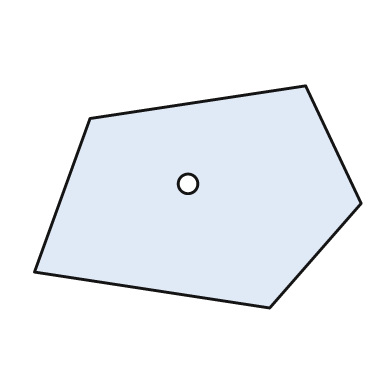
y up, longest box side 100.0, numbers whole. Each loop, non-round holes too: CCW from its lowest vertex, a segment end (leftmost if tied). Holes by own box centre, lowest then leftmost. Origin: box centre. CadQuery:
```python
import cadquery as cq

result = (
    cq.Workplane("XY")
    .moveTo(22.0, -34.0)
    .lineTo(50.0, -2.0)
    .lineTo(33.0, 34.0)
    .lineTo(-33.0, 24.0)
    .lineTo(-50.0, -23.0)
    .close()
    .moveTo(-3.0, 4.0)
    .circle(3.0)
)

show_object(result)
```